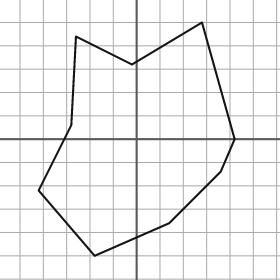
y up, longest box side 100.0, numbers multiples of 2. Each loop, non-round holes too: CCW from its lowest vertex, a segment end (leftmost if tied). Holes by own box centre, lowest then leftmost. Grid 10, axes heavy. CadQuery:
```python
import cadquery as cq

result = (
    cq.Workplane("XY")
    .moveTo(-18.0, -50.0)
    .lineTo(14.0, -36.0)
    .lineTo(36.0, -14.0)
    .lineTo(42.0, 0.0)
    .lineTo(28.0, 50.0)
    .lineTo(-2.0, 32.0)
    .lineTo(-26.0, 44.0)
    .lineTo(-28.0, 6.0)
    .lineTo(-42.0, -22.0)
    .close()
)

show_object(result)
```